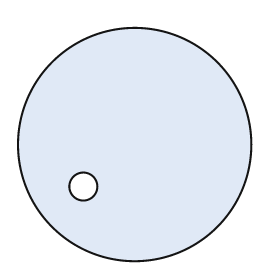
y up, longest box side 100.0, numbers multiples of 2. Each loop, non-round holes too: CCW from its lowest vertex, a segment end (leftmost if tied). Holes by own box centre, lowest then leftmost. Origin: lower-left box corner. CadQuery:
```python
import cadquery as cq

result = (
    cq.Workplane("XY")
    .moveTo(50.0, 50.0)
    .circle(50.0)
    .moveTo(28.0, 32.0)
    .circle(6.0)
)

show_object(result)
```